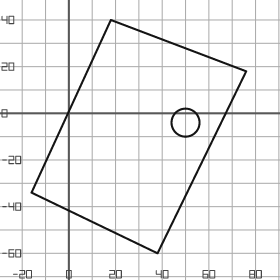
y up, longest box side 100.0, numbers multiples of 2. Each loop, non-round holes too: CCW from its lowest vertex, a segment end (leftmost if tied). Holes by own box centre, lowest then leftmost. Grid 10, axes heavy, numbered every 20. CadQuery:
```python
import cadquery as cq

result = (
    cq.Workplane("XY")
    .moveTo(38.0, -60.0)
    .lineTo(76.0, 18.0)
    .lineTo(18.0, 40.0)
    .lineTo(-16.0, -34.0)
    .close()
    .moveTo(50.0, -4.0)
    .circle(6.0)
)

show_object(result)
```